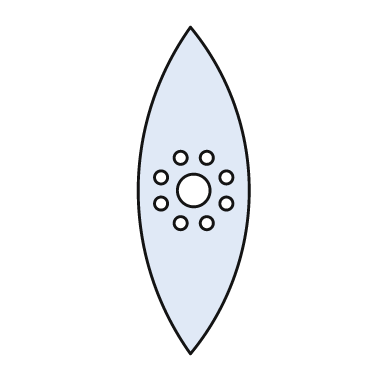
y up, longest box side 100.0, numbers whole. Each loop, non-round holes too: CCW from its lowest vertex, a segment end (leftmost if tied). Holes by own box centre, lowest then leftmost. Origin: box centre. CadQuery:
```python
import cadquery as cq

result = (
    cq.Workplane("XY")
    .moveTo(-1.0, -50.0)
    .threePointArc((17.0, 0.0), (-1.0, 50.0))
    .threePointArc((-17.0, 0.0), (-1.0, -50.0))
    .close()
    .moveTo(-4.0, -10.0)
    .circle(2.0)
    .moveTo(4.0, -10.0)
    .circle(2.0)
    .moveTo(-10.0, -4.0)
    .circle(2.0)
    .moveTo(10.0, -4.0)
    .circle(2.0)
    .moveTo(0.0, 0.0)
    .circle(5.0)
    .moveTo(-10.0, 4.0)
    .circle(2.0)
    .moveTo(10.0, 4.0)
    .circle(2.0)
    .moveTo(-4.0, 10.0)
    .circle(2.0)
    .moveTo(4.0, 10.0)
    .circle(2.0)
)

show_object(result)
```